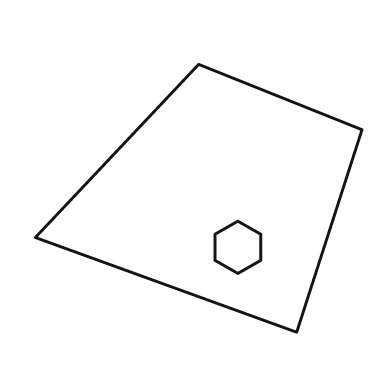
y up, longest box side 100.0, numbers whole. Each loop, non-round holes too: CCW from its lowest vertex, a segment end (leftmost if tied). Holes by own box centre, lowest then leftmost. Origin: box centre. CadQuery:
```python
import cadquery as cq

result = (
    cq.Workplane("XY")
    .moveTo(30.0, -41.0)
    .lineTo(50.0, 21.0)
    .lineTo(0.0, 41.0)
    .lineTo(-50.0, -12.0)
    .close()
    .moveTo(12.0, -23.0)
    .lineTo(19.0, -19.0)
    .lineTo(19.0, -11.0)
    .lineTo(12.0, -7.0)
    .lineTo(5.0, -11.0)
    .lineTo(5.0, -19.0)
    .close()
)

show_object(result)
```